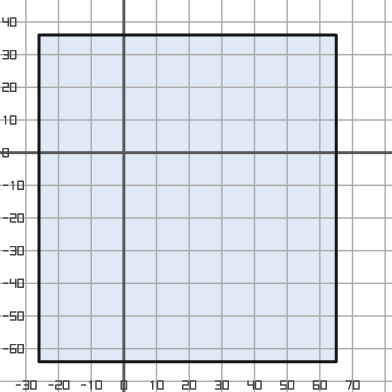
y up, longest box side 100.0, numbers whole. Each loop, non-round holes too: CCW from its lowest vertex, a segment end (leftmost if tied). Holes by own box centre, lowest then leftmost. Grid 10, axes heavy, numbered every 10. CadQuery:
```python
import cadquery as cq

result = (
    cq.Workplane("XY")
    .moveTo(-26.0, -64.0)
    .lineTo(65.0, -64.0)
    .lineTo(65.0, 36.0)
    .lineTo(-26.0, 36.0)
    .close()
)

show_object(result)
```